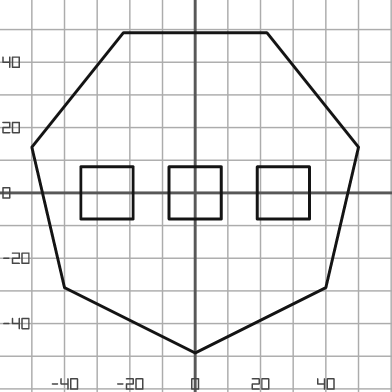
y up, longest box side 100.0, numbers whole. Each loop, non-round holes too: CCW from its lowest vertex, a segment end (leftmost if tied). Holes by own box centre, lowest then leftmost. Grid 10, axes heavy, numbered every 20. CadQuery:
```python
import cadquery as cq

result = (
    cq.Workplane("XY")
    .moveTo(0.0, -49.0)
    .lineTo(40.0, -29.0)
    .lineTo(50.0, 14.0)
    .lineTo(22.0, 49.0)
    .lineTo(-22.0, 49.0)
    .lineTo(-50.0, 14.0)
    .lineTo(-40.0, -29.0)
    .close()
    .moveTo(-35.0, -8.0)
    .lineTo(-19.0, -8.0)
    .lineTo(-19.0, 8.0)
    .lineTo(-35.0, 8.0)
    .close()
    .moveTo(-8.0, -8.0)
    .lineTo(8.0, -8.0)
    .lineTo(8.0, 8.0)
    .lineTo(-8.0, 8.0)
    .close()
    .moveTo(19.0, -8.0)
    .lineTo(35.0, -8.0)
    .lineTo(35.0, 8.0)
    .lineTo(19.0, 8.0)
    .close()
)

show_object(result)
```